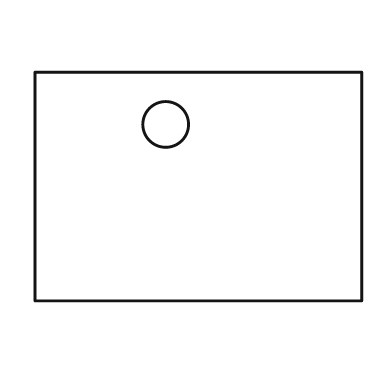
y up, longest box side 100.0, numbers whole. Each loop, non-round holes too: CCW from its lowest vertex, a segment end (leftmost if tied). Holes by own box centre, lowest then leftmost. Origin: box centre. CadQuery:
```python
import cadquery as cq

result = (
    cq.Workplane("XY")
    .moveTo(-50.0, -35.0)
    .lineTo(50.0, -35.0)
    .lineTo(50.0, 35.0)
    .lineTo(-50.0, 35.0)
    .close()
    .moveTo(-10.0, 19.0)
    .circle(7.0)
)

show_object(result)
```